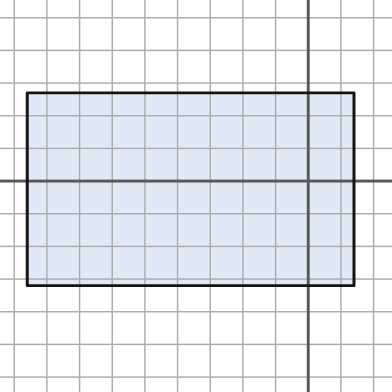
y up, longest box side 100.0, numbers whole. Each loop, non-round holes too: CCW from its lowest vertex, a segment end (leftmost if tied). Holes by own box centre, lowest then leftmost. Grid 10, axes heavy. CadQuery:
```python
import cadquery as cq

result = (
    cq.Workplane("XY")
    .moveTo(-86.0, -32.0)
    .lineTo(14.0, -32.0)
    .lineTo(14.0, 27.0)
    .lineTo(-86.0, 27.0)
    .close()
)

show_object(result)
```